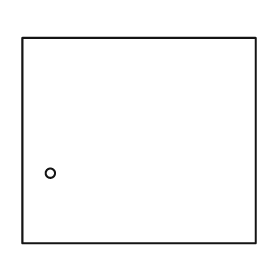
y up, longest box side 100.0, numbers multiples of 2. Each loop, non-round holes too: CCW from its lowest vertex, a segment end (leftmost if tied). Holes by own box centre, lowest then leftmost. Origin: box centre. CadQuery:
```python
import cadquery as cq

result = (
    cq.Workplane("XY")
    .moveTo(-50.0, -44.0)
    .lineTo(50.0, -44.0)
    .lineTo(50.0, 44.0)
    .lineTo(-50.0, 44.0)
    .close()
    .moveTo(-38.0, -14.0)
    .circle(2.0)
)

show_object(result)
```